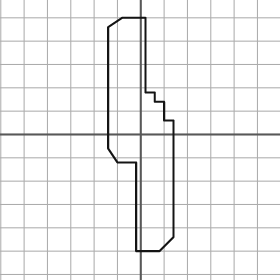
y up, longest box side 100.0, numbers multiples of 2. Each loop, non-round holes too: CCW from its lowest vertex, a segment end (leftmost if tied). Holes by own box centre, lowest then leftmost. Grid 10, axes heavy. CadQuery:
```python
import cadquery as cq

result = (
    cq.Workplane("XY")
    .moveTo(-2.0, -50.0)
    .lineTo(8.0, -50.0)
    .lineTo(14.0, -44.0)
    .lineTo(14.0, 6.0)
    .lineTo(10.0, 6.0)
    .lineTo(10.0, 14.0)
    .lineTo(6.0, 14.0)
    .lineTo(6.0, 18.0)
    .lineTo(2.0, 18.0)
    .lineTo(2.0, 50.0)
    .lineTo(-8.0, 50.0)
    .lineTo(-14.0, 46.0)
    .lineTo(-14.0, -6.0)
    .lineTo(-10.0, -12.0)
    .lineTo(-2.0, -12.0)
    .close()
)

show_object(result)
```